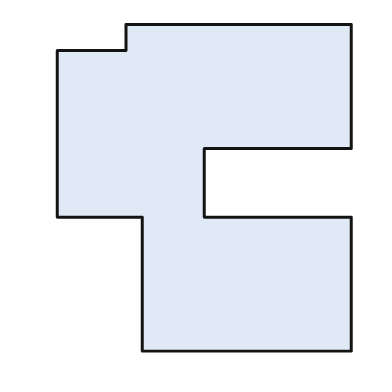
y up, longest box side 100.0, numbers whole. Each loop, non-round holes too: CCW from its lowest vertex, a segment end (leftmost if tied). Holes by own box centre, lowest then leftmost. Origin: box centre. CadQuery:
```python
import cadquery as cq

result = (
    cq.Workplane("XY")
    .moveTo(-19.0, -50.0)
    .lineTo(45.0, -50.0)
    .lineTo(45.0, -9.0)
    .lineTo(0.0, -9.0)
    .lineTo(0.0, 12.0)
    .lineTo(45.0, 12.0)
    .lineTo(45.0, 50.0)
    .lineTo(-24.0, 50.0)
    .lineTo(-24.0, 42.0)
    .lineTo(-45.0, 42.0)
    .lineTo(-45.0, -9.0)
    .lineTo(-19.0, -9.0)
    .close()
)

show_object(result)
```